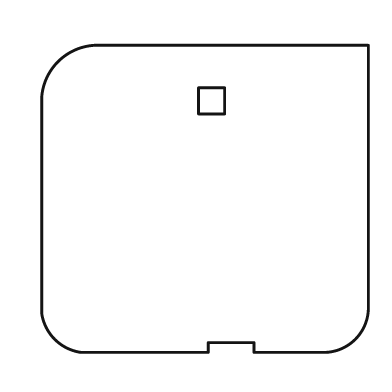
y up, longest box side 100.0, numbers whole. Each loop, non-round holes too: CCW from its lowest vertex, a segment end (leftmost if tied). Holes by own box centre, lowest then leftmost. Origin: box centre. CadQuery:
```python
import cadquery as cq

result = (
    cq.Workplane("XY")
    .moveTo(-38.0, -47.0)
    .lineTo(1.0, -47.0)
    .lineTo(1.0, -44.0)
    .lineTo(15.0, -44.0)
    .lineTo(15.0, -47.0)
    .lineTo(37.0, -47.0)
    .threePointArc((46.0, -43.0), (50.0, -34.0))
    .lineTo(50.0, 47.0)
    .lineTo(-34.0, 47.0)
    .threePointArc((-45.0, 42.0), (-50.0, 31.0))
    .lineTo(-50.0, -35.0)
    .threePointArc((-46.0, -43.0), (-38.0, -47.0))
    .close()
    .moveTo(-2.0, 26.0)
    .lineTo(6.0, 26.0)
    .lineTo(6.0, 34.0)
    .lineTo(-2.0, 34.0)
    .close()
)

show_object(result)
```